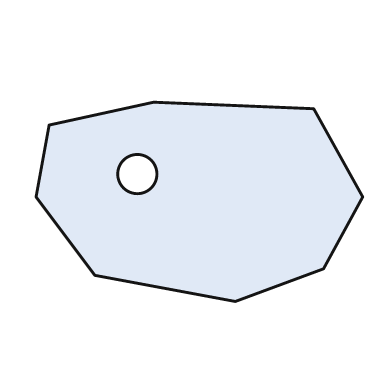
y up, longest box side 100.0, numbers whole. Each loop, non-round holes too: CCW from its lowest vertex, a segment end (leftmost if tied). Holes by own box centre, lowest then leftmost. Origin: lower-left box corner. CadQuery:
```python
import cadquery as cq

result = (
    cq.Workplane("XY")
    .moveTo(61.0, 0.0)
    .lineTo(88.0, 10.0)
    .lineTo(100.0, 32.0)
    .lineTo(85.0, 59.0)
    .lineTo(36.0, 61.0)
    .lineTo(4.0, 54.0)
    .lineTo(0.0, 32.0)
    .lineTo(18.0, 8.0)
    .close()
    .moveTo(31.0, 39.0)
    .circle(6.0)
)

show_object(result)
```